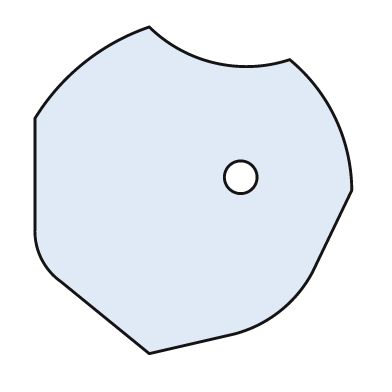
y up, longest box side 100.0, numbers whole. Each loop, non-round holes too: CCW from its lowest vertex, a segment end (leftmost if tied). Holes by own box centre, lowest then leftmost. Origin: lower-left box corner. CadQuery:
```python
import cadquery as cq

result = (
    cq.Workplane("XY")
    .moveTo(35.0, 0.0)
    .lineTo(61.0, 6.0)
    .threePointArc((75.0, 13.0), (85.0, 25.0))
    .lineTo(97.0, 50.0)
    .threePointArc((92.0, 72.0), (78.0, 90.0))
    .threePointArc((55.0, 89.0), (35.0, 100.0))
    .threePointArc((15.0, 89.0), (0.0, 72.0))
    .lineTo(0.0, 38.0)
    .threePointArc((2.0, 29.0), (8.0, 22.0))
    .close()
    .moveTo(63.0, 54.0)
    .circle(5.0)
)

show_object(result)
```